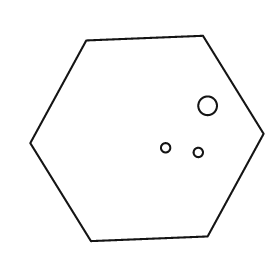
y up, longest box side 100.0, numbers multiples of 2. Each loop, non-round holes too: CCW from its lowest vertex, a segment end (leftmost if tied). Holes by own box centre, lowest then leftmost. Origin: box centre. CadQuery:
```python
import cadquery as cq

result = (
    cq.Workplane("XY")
    .moveTo(-24.0, -44.0)
    .lineTo(26.0, -42.0)
    .lineTo(50.0, 2.0)
    .lineTo(24.0, 44.0)
    .lineTo(-26.0, 42.0)
    .lineTo(-50.0, -2.0)
    .close()
    .moveTo(22.0, -6.0)
    .circle(2.0)
    .moveTo(8.0, -4.0)
    .circle(2.0)
    .moveTo(26.0, 14.0)
    .circle(4.0)
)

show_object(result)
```